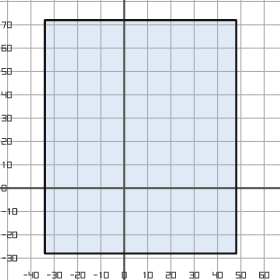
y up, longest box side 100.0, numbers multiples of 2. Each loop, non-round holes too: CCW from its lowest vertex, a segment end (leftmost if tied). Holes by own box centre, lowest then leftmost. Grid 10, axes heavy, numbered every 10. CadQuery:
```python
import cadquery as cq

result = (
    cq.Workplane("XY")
    .moveTo(-34.0, -28.0)
    .lineTo(48.0, -28.0)
    .lineTo(48.0, 72.0)
    .lineTo(-34.0, 72.0)
    .close()
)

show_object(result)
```